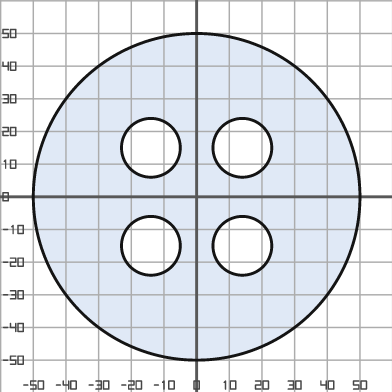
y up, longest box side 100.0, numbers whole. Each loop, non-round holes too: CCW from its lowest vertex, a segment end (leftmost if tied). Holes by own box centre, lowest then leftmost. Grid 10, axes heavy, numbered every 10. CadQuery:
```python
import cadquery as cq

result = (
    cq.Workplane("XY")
    .moveTo(0.0, 0.0)
    .circle(50.0)
    .moveTo(-14.0, -15.0)
    .circle(9.0)
    .moveTo(14.0, -15.0)
    .circle(9.0)
    .moveTo(-14.0, 15.0)
    .circle(9.0)
    .moveTo(14.0, 15.0)
    .circle(9.0)
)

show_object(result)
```